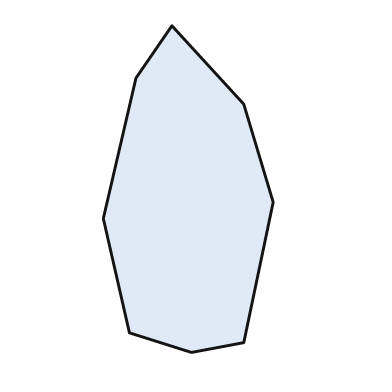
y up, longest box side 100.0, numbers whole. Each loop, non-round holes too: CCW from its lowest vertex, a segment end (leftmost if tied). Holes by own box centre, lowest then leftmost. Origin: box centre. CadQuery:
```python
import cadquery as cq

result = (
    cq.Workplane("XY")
    .moveTo(1.0, -50.0)
    .lineTo(17.0, -47.0)
    .lineTo(26.0, -4.0)
    .lineTo(17.0, 26.0)
    .lineTo(-5.0, 50.0)
    .lineTo(-16.0, 34.0)
    .lineTo(-26.0, -9.0)
    .lineTo(-18.0, -44.0)
    .close()
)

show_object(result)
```